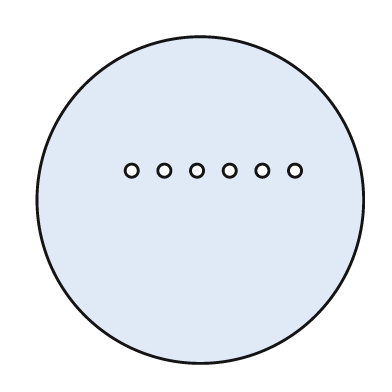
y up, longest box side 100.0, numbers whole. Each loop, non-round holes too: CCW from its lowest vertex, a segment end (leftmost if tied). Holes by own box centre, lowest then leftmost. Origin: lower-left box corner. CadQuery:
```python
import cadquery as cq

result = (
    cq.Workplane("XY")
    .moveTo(50.0, 50.0)
    .circle(50.0)
    .moveTo(29.0, 59.0)
    .circle(2.0)
    .moveTo(39.0, 59.0)
    .circle(2.0)
    .moveTo(49.0, 59.0)
    .circle(2.0)
    .moveTo(59.0, 59.0)
    .circle(2.0)
    .moveTo(69.0, 59.0)
    .circle(2.0)
    .moveTo(79.0, 59.0)
    .circle(2.0)
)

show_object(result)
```